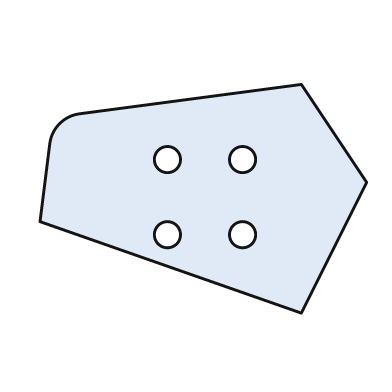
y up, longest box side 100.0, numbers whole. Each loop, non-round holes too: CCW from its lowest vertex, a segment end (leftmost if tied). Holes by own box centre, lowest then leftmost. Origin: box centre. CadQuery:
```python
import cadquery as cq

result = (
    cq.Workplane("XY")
    .moveTo(30.0, -35.0)
    .lineTo(50.0, 5.0)
    .lineTo(30.0, 35.0)
    .lineTo(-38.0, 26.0)
    .threePointArc((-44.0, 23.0), (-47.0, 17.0))
    .lineTo(-50.0, -7.0)
    .close()
    .moveTo(-11.0, -11.0)
    .circle(4.0)
    .moveTo(12.0, -11.0)
    .circle(4.0)
    .moveTo(-11.0, 12.0)
    .circle(4.0)
    .moveTo(12.0, 12.0)
    .circle(4.0)
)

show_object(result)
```